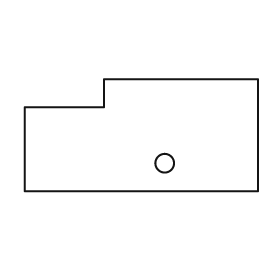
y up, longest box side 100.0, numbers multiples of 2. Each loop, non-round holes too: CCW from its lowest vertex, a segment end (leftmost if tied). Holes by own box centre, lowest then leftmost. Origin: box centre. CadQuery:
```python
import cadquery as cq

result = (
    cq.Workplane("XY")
    .moveTo(-50.0, -24.0)
    .lineTo(50.0, -24.0)
    .lineTo(50.0, 24.0)
    .lineTo(-16.0, 24.0)
    .lineTo(-16.0, 12.0)
    .lineTo(-50.0, 12.0)
    .close()
    .moveTo(10.0, -12.0)
    .circle(4.0)
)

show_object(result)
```